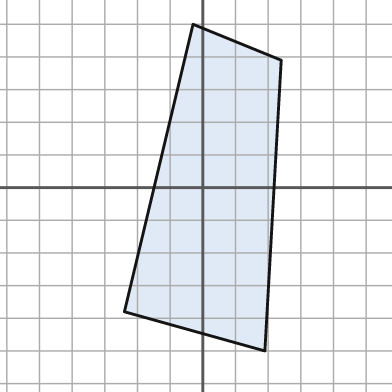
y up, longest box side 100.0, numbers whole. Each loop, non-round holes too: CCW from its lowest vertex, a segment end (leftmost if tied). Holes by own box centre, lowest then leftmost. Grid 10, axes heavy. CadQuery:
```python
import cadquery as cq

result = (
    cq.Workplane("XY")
    .moveTo(19.0, -50.0)
    .lineTo(24.0, 39.0)
    .lineTo(-3.0, 50.0)
    .lineTo(-24.0, -38.0)
    .close()
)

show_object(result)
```